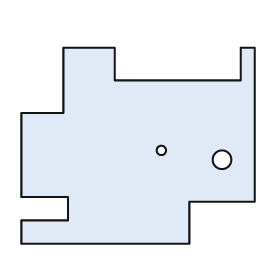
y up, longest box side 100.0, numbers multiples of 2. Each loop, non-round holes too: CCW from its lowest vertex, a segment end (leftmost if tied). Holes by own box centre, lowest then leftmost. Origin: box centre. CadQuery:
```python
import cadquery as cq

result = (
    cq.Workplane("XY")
    .moveTo(-50.0, -42.0)
    .lineTo(22.0, -42.0)
    .lineTo(22.0, -24.0)
    .lineTo(50.0, -24.0)
    .lineTo(50.0, 42.0)
    .lineTo(44.0, 42.0)
    .lineTo(44.0, 28.0)
    .lineTo(-10.0, 28.0)
    .lineTo(-10.0, 42.0)
    .lineTo(-32.0, 42.0)
    .lineTo(-32.0, 14.0)
    .lineTo(-50.0, 14.0)
    .lineTo(-50.0, -22.0)
    .lineTo(-30.0, -22.0)
    .lineTo(-30.0, -32.0)
    .lineTo(-50.0, -32.0)
    .close()
    .moveTo(36.0, -6.0)
    .circle(4.0)
    .moveTo(10.0, -2.0)
    .circle(2.0)
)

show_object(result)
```